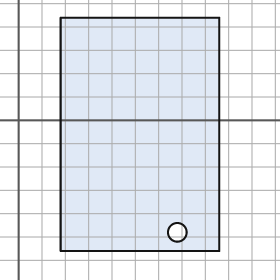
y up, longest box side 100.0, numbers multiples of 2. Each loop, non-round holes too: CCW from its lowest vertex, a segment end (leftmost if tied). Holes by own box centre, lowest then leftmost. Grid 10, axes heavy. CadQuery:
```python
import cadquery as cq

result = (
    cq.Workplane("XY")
    .moveTo(18.0, -56.0)
    .lineTo(86.0, -56.0)
    .lineTo(86.0, 44.0)
    .lineTo(18.0, 44.0)
    .close()
    .moveTo(68.0, -48.0)
    .circle(4.0)
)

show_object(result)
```